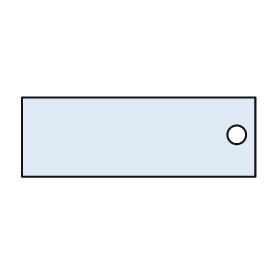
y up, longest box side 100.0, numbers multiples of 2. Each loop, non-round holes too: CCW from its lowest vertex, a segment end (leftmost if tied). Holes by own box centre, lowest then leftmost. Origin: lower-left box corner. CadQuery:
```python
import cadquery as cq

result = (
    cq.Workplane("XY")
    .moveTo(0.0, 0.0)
    .lineTo(100.0, 0.0)
    .lineTo(100.0, 34.0)
    .lineTo(0.0, 34.0)
    .close()
    .moveTo(92.0, 18.0)
    .circle(4.0)
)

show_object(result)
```